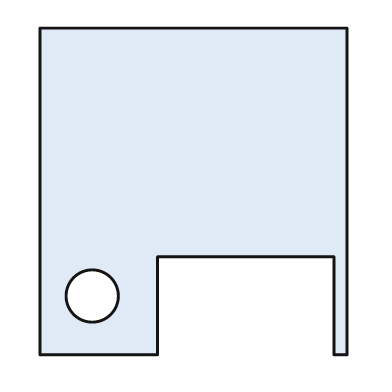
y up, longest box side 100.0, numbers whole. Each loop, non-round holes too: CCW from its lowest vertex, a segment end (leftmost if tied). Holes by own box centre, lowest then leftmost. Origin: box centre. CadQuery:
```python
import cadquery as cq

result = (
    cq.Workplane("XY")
    .moveTo(-47.0, -50.0)
    .lineTo(-11.0, -50.0)
    .lineTo(-11.0, -20.0)
    .lineTo(43.0, -20.0)
    .lineTo(43.0, -50.0)
    .lineTo(47.0, -50.0)
    .lineTo(47.0, 50.0)
    .lineTo(-47.0, 50.0)
    .close()
    .moveTo(-31.0, -32.0)
    .circle(8.0)
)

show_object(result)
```